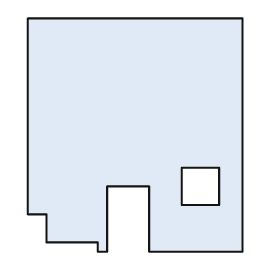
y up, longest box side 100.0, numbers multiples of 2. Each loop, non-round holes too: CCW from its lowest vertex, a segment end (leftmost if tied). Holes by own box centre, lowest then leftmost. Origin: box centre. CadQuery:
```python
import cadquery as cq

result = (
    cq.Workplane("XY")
    .moveTo(-16.0, -50.0)
    .lineTo(-12.0, -50.0)
    .lineTo(-12.0, -22.0)
    .lineTo(6.0, -22.0)
    .lineTo(6.0, -50.0)
    .lineTo(46.0, -50.0)
    .lineTo(46.0, 50.0)
    .lineTo(-46.0, 50.0)
    .lineTo(-46.0, -34.0)
    .lineTo(-38.0, -34.0)
    .lineTo(-38.0, -46.0)
    .lineTo(-16.0, -46.0)
    .close()
    .moveTo(20.0, -30.0)
    .lineTo(36.0, -30.0)
    .lineTo(36.0, -14.0)
    .lineTo(20.0, -14.0)
    .close()
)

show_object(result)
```